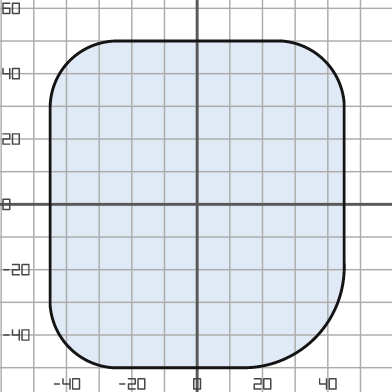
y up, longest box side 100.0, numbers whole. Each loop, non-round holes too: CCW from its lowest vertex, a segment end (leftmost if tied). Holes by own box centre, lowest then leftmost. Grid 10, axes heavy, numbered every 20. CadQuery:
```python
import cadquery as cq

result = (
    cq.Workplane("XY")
    .moveTo(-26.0, -50.0)
    .lineTo(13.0, -50.0)
    .threePointArc((36.0, -41.0), (45.0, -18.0))
    .lineTo(45.0, 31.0)
    .threePointArc((39.0, 44.0), (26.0, 50.0))
    .lineTo(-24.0, 50.0)
    .threePointArc((-39.0, 44.0), (-45.0, 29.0))
    .lineTo(-45.0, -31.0)
    .threePointArc((-39.0, -44.0), (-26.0, -50.0))
    .close()
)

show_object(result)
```